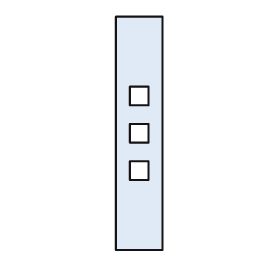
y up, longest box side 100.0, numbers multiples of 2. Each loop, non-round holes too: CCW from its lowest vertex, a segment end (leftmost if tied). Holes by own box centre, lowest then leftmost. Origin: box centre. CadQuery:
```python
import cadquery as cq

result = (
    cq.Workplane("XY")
    .moveTo(-10.0, -50.0)
    .lineTo(10.0, -50.0)
    .lineTo(10.0, 50.0)
    .lineTo(-10.0, 50.0)
    .close()
    .moveTo(-4.0, -20.0)
    .lineTo(4.0, -20.0)
    .lineTo(4.0, -12.0)
    .lineTo(-4.0, -12.0)
    .close()
    .moveTo(-4.0, -4.0)
    .lineTo(4.0, -4.0)
    .lineTo(4.0, 4.0)
    .lineTo(-4.0, 4.0)
    .close()
    .moveTo(-4.0, 12.0)
    .lineTo(4.0, 12.0)
    .lineTo(4.0, 20.0)
    .lineTo(-4.0, 20.0)
    .close()
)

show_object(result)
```